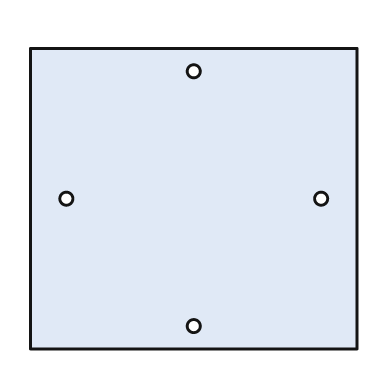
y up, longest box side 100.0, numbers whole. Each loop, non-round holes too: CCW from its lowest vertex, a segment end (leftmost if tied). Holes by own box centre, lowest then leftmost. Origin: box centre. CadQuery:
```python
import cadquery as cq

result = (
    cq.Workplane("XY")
    .moveTo(-50.0, -46.0)
    .lineTo(50.0, -46.0)
    .lineTo(50.0, 46.0)
    .lineTo(-50.0, 46.0)
    .close()
    .moveTo(0.0, -39.0)
    .circle(2.0)
    .moveTo(-39.0, 0.0)
    .circle(2.0)
    .moveTo(39.0, 0.0)
    .circle(2.0)
    .moveTo(0.0, 39.0)
    .circle(2.0)
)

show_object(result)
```